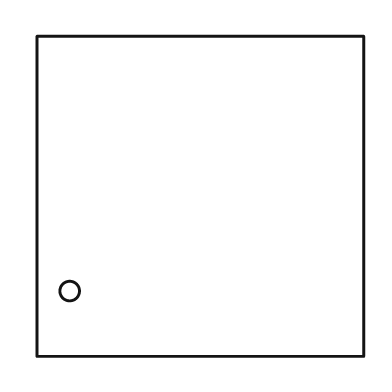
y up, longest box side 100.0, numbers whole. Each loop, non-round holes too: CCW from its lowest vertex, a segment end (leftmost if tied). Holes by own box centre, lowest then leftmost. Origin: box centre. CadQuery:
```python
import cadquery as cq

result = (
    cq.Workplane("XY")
    .moveTo(-50.0, -49.0)
    .lineTo(50.0, -49.0)
    .lineTo(50.0, 49.0)
    .lineTo(-50.0, 49.0)
    .close()
    .moveTo(-40.0, -29.0)
    .circle(3.0)
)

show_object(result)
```